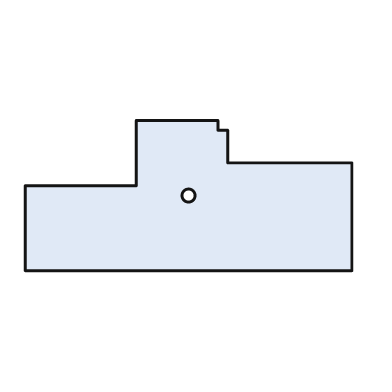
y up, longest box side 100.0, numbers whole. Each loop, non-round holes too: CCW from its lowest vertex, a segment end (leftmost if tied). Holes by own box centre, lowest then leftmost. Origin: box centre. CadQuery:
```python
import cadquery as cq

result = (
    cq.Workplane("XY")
    .moveTo(-50.0, -23.0)
    .lineTo(50.0, -23.0)
    .lineTo(50.0, 10.0)
    .lineTo(12.0, 10.0)
    .lineTo(12.0, 20.0)
    .lineTo(9.0, 20.0)
    .lineTo(9.0, 23.0)
    .lineTo(-16.0, 23.0)
    .lineTo(-16.0, 3.0)
    .lineTo(-50.0, 3.0)
    .close()
    .moveTo(0.0, 0.0)
    .circle(2.0)
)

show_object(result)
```